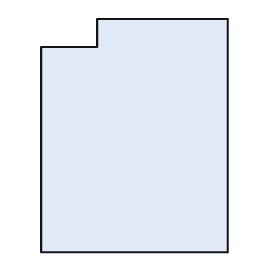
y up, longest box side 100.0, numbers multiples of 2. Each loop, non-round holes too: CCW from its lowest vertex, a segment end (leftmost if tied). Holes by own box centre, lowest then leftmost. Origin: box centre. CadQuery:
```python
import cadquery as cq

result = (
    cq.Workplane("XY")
    .moveTo(-40.0, -50.0)
    .lineTo(40.0, -50.0)
    .lineTo(40.0, 50.0)
    .lineTo(-16.0, 50.0)
    .lineTo(-16.0, 38.0)
    .lineTo(-40.0, 38.0)
    .close()
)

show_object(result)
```